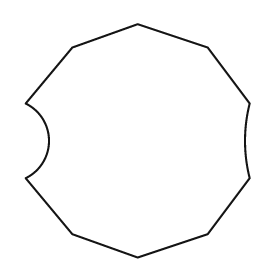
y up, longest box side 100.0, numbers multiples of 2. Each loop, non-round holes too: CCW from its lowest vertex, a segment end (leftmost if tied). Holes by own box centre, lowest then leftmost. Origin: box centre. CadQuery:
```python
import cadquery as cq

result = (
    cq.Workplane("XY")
    .moveTo(0.0, -50.0)
    .lineTo(30.0, -40.0)
    .lineTo(48.0, -16.0)
    .threePointArc((46.0, 0.0), (48.0, 16.0))
    .lineTo(30.0, 40.0)
    .lineTo(0.0, 50.0)
    .lineTo(-28.0, 40.0)
    .lineTo(-48.0, 16.0)
    .threePointArc((-38.0, 0.0), (-48.0, -16.0))
    .lineTo(-28.0, -40.0)
    .close()
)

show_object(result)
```